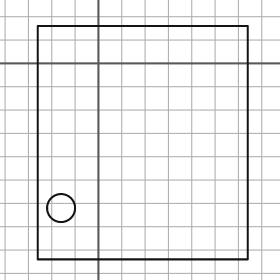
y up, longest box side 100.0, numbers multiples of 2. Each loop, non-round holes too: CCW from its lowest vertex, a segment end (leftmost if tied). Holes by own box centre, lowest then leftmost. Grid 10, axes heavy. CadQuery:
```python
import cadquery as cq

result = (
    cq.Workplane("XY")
    .moveTo(-26.0, -84.0)
    .lineTo(64.0, -84.0)
    .lineTo(64.0, 16.0)
    .lineTo(-26.0, 16.0)
    .close()
    .moveTo(-16.0, -62.0)
    .circle(6.0)
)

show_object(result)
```